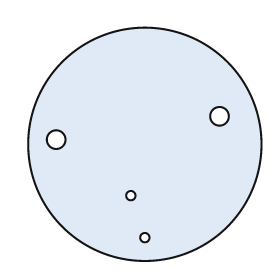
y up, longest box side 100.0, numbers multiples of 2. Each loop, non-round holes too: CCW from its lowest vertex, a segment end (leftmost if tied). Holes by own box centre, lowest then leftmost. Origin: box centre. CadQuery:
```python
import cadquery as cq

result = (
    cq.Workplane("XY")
    .moveTo(0.0, 0.0)
    .circle(50.0)
    .moveTo(0.0, -40.0)
    .circle(2.0)
    .moveTo(-6.0, -22.0)
    .circle(2.0)
    .moveTo(-38.0, 2.0)
    .circle(4.0)
    .moveTo(32.0, 12.0)
    .circle(4.0)
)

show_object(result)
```